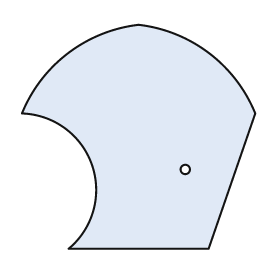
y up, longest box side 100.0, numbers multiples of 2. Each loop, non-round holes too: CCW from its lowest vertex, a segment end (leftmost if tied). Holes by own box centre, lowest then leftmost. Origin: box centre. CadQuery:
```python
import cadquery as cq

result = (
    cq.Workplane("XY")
    .moveTo(-30.0, -48.0)
    .lineTo(30.0, -48.0)
    .lineTo(50.0, 10.0)
    .threePointArc((30.0, 36.0), (0.0, 48.0))
    .threePointArc((-30.0, 36.0), (-50.0, 10.0))
    .threePointArc((-20.0, -12.0), (-30.0, -48.0))
    .close()
    .moveTo(20.0, -14.0)
    .circle(2.0)
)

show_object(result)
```